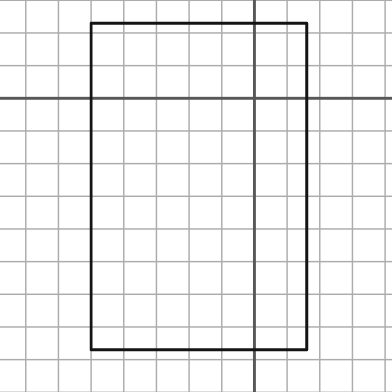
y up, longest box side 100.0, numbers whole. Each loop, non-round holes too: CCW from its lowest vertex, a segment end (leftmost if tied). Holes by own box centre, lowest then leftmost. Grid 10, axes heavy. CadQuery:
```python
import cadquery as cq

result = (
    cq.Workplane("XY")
    .moveTo(-50.0, -77.0)
    .lineTo(16.0, -77.0)
    .lineTo(16.0, 23.0)
    .lineTo(-50.0, 23.0)
    .close()
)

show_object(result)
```